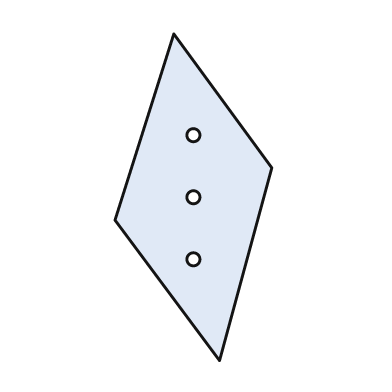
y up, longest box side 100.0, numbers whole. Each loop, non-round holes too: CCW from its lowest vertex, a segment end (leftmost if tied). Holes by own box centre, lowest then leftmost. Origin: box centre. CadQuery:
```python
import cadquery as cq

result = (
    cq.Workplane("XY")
    .moveTo(8.0, -50.0)
    .lineTo(24.0, 9.0)
    .lineTo(-6.0, 50.0)
    .lineTo(-24.0, -7.0)
    .close()
    .moveTo(0.0, -19.0)
    .circle(2.0)
    .moveTo(0.0, 0.0)
    .circle(2.0)
    .moveTo(0.0, 19.0)
    .circle(2.0)
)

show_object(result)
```